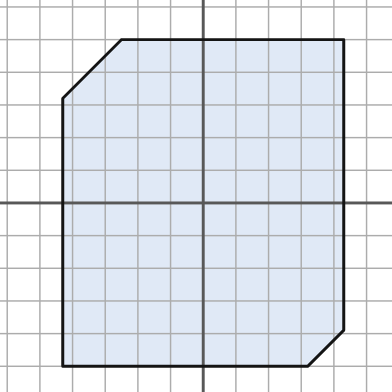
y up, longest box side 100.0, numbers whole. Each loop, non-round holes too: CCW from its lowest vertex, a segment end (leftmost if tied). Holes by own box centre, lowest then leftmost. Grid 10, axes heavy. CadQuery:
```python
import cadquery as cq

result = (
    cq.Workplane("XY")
    .moveTo(-43.0, -50.0)
    .lineTo(32.0, -50.0)
    .lineTo(43.0, -39.0)
    .lineTo(43.0, 50.0)
    .lineTo(-25.0, 50.0)
    .lineTo(-43.0, 32.0)
    .close()
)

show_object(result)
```